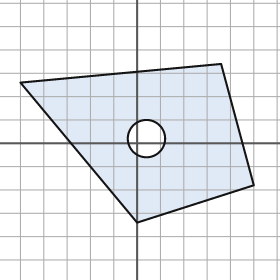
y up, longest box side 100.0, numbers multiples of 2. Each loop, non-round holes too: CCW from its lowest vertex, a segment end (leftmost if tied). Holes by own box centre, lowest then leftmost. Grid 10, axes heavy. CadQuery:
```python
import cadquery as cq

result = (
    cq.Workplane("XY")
    .moveTo(0.0, -34.0)
    .lineTo(50.0, -18.0)
    .lineTo(36.0, 34.0)
    .lineTo(-50.0, 26.0)
    .close()
    .moveTo(4.0, 2.0)
    .circle(8.0)
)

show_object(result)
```